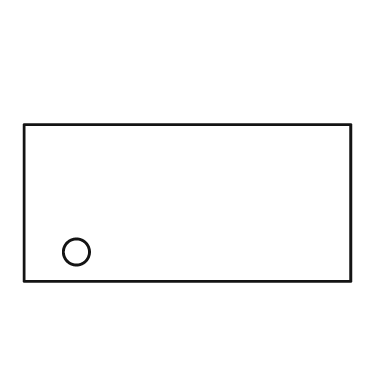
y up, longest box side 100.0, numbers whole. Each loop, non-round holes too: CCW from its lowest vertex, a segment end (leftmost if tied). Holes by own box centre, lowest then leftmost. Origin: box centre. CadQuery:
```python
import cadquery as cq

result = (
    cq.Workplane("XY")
    .moveTo(-50.0, -24.0)
    .lineTo(50.0, -24.0)
    .lineTo(50.0, 24.0)
    .lineTo(-50.0, 24.0)
    .close()
    .moveTo(-34.0, -15.0)
    .circle(4.0)
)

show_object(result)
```